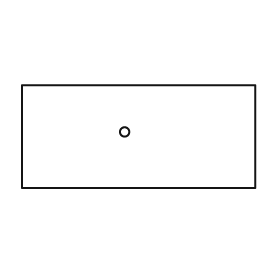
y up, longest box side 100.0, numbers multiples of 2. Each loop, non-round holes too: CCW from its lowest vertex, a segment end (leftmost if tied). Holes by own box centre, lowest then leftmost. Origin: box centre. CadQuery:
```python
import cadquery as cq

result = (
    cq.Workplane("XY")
    .moveTo(-50.0, -22.0)
    .lineTo(50.0, -22.0)
    .lineTo(50.0, 22.0)
    .lineTo(-50.0, 22.0)
    .close()
    .moveTo(-6.0, 2.0)
    .circle(2.0)
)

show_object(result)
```